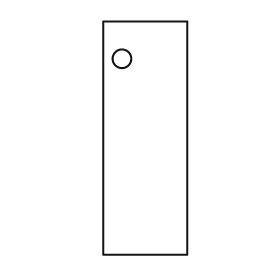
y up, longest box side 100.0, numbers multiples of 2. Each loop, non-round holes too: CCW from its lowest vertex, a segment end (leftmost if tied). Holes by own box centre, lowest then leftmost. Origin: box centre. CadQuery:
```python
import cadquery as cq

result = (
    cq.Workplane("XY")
    .moveTo(-18.0, -50.0)
    .lineTo(18.0, -50.0)
    .lineTo(18.0, 50.0)
    .lineTo(-18.0, 50.0)
    .close()
    .moveTo(-10.0, 34.0)
    .circle(4.0)
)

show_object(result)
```